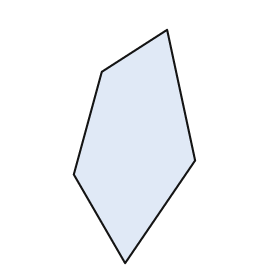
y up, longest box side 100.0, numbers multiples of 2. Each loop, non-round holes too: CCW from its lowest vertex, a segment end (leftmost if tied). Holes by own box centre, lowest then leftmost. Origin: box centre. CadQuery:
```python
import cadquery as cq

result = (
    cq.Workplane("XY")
    .moveTo(-4.0, -50.0)
    .lineTo(26.0, -6.0)
    .lineTo(14.0, 50.0)
    .lineTo(-14.0, 32.0)
    .lineTo(-26.0, -12.0)
    .close()
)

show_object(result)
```